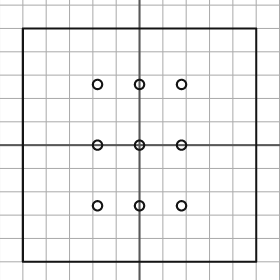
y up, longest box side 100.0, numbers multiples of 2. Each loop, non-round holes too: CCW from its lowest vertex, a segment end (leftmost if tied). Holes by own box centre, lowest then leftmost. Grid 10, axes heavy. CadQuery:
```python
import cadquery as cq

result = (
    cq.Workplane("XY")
    .moveTo(-50.0, -50.0)
    .lineTo(50.0, -50.0)
    .lineTo(50.0, 50.0)
    .lineTo(-50.0, 50.0)
    .close()
    .moveTo(-18.0, -26.0)
    .circle(2.0)
    .moveTo(0.0, -26.0)
    .circle(2.0)
    .moveTo(18.0, -26.0)
    .circle(2.0)
    .moveTo(-18.0, 0.0)
    .circle(2.0)
    .moveTo(0.0, 0.0)
    .circle(2.0)
    .moveTo(18.0, 0.0)
    .circle(2.0)
    .moveTo(-18.0, 26.0)
    .circle(2.0)
    .moveTo(0.0, 26.0)
    .circle(2.0)
    .moveTo(18.0, 26.0)
    .circle(2.0)
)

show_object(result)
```